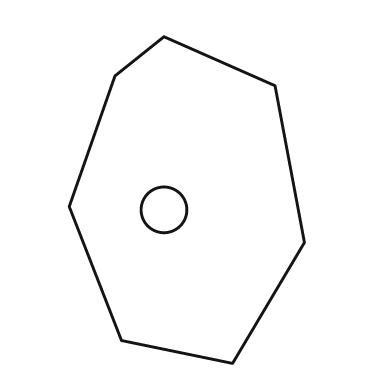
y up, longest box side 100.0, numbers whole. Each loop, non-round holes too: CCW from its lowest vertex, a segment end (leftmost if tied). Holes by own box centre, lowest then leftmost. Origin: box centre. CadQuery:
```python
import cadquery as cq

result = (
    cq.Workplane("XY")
    .moveTo(14.0, -50.0)
    .lineTo(36.0, -13.0)
    .lineTo(27.0, 35.0)
    .lineTo(-7.0, 50.0)
    .lineTo(-22.0, 38.0)
    .lineTo(-36.0, -2.0)
    .lineTo(-20.0, -43.0)
    .close()
    .moveTo(-7.0, -3.0)
    .circle(7.0)
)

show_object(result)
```